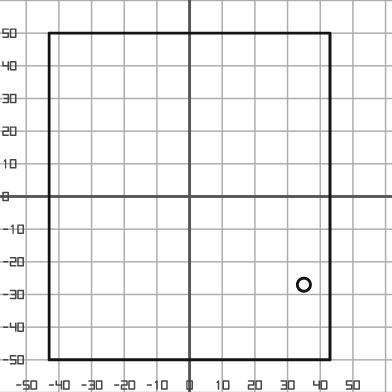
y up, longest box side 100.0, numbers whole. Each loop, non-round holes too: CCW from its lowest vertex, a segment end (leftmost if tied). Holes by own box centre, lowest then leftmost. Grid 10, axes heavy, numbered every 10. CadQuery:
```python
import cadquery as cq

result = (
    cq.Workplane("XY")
    .moveTo(-43.0, -50.0)
    .lineTo(43.0, -50.0)
    .lineTo(43.0, 50.0)
    .lineTo(-43.0, 50.0)
    .close()
    .moveTo(35.0, -27.0)
    .circle(2.0)
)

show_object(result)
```